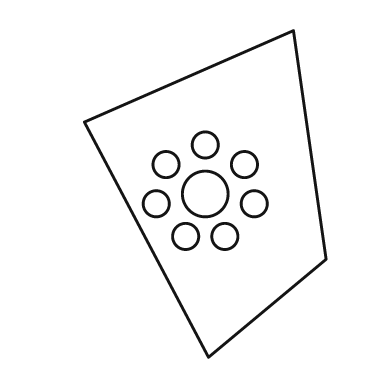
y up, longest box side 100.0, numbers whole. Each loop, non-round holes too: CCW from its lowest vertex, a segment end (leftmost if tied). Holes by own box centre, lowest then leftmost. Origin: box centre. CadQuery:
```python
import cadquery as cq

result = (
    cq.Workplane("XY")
    .moveTo(1.0, -50.0)
    .lineTo(37.0, -20.0)
    .lineTo(27.0, 50.0)
    .lineTo(-37.0, 22.0)
    .close()
    .moveTo(-6.0, -13.0)
    .circle(4.0)
    .moveTo(6.0, -13.0)
    .circle(4.0)
    .moveTo(-15.0, -3.0)
    .circle(4.0)
    .moveTo(15.0, -3.0)
    .circle(4.0)
    .moveTo(0.0, 0.0)
    .circle(7.0)
    .moveTo(-12.0, 9.0)
    .circle(4.0)
    .moveTo(12.0, 9.0)
    .circle(4.0)
    .moveTo(0.0, 15.0)
    .circle(4.0)
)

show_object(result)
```